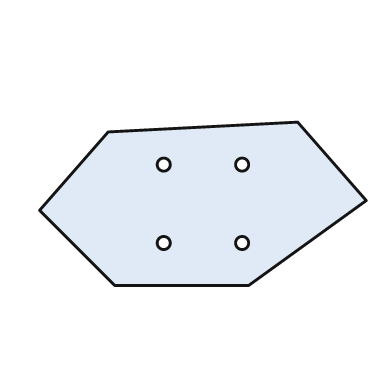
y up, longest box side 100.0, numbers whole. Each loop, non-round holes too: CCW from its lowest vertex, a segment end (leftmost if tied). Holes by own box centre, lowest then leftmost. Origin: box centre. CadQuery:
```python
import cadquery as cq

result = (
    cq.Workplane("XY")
    .moveTo(-27.0, -25.0)
    .lineTo(14.0, -25.0)
    .lineTo(50.0, 1.0)
    .lineTo(29.0, 25.0)
    .lineTo(-29.0, 22.0)
    .lineTo(-50.0, -2.0)
    .close()
    .moveTo(-12.0, -12.0)
    .circle(2.0)
    .moveTo(12.0, -12.0)
    .circle(2.0)
    .moveTo(-12.0, 12.0)
    .circle(2.0)
    .moveTo(12.0, 12.0)
    .circle(2.0)
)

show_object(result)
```